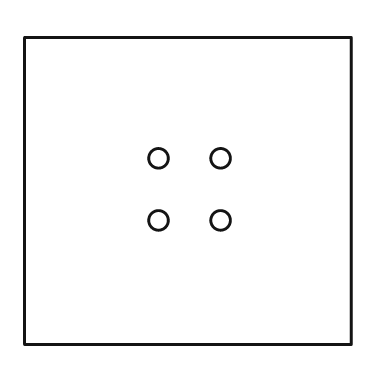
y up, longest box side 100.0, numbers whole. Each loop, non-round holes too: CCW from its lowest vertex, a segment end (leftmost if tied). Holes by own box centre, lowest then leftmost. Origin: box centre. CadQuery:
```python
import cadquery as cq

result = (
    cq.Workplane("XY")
    .moveTo(-50.0, -47.0)
    .lineTo(50.0, -47.0)
    .lineTo(50.0, 47.0)
    .lineTo(-50.0, 47.0)
    .close()
    .moveTo(-9.0, -9.0)
    .circle(3.0)
    .moveTo(10.0, -9.0)
    .circle(3.0)
    .moveTo(-9.0, 10.0)
    .circle(3.0)
    .moveTo(10.0, 10.0)
    .circle(3.0)
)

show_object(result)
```